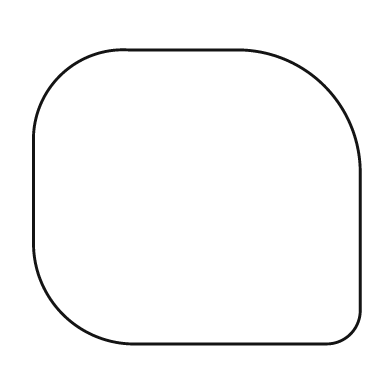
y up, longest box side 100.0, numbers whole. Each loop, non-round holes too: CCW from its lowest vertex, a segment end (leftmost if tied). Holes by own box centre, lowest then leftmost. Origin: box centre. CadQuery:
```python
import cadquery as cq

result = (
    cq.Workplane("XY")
    .moveTo(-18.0, -45.0)
    .lineTo(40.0, -45.0)
    .threePointArc((47.0, -42.0), (50.0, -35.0))
    .lineTo(50.0, 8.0)
    .threePointArc((39.0, 34.0), (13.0, 45.0))
    .lineTo(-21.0, 45.0)
    .threePointArc((-42.0, 37.0), (-50.0, 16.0))
    .lineTo(-50.0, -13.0)
    .threePointArc((-41.0, -36.0), (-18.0, -45.0))
    .close()
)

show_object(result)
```